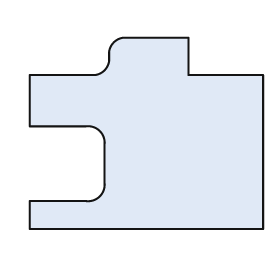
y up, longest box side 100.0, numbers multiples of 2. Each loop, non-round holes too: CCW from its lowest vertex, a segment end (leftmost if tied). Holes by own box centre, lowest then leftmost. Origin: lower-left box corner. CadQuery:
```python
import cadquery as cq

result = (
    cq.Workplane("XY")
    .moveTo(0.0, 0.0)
    .lineTo(100.0, 0.0)
    .lineTo(100.0, 66.0)
    .lineTo(68.0, 66.0)
    .lineTo(68.0, 82.0)
    .lineTo(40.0, 82.0)
    .threePointArc((36.0, 80.0), (34.0, 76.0))
    .lineTo(34.0, 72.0)
    .threePointArc((32.0, 68.0), (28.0, 66.0))
    .lineTo(0.0, 66.0)
    .lineTo(0.0, 44.0)
    .lineTo(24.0, 44.0)
    .threePointArc((30.0, 42.0), (32.0, 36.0))
    .lineTo(32.0, 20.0)
    .threePointArc((30.0, 14.0), (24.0, 12.0))
    .lineTo(0.0, 12.0)
    .close()
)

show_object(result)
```